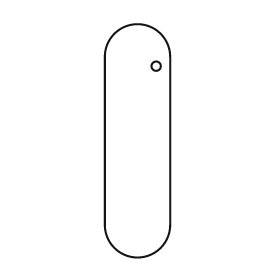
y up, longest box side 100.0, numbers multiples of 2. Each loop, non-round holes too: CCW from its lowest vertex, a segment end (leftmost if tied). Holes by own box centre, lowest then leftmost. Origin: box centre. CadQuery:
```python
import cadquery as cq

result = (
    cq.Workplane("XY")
    .moveTo(-14.0, -36.0)
    .threePointArc((0.0, -50.0), (14.0, -36.0))
    .lineTo(14.0, 36.0)
    .threePointArc((0.0, 50.0), (-14.0, 36.0))
    .close()
    .moveTo(8.0, 32.0)
    .circle(2.0)
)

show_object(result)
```